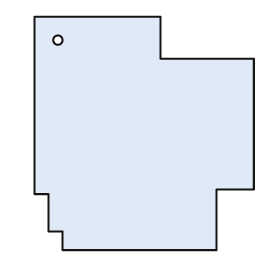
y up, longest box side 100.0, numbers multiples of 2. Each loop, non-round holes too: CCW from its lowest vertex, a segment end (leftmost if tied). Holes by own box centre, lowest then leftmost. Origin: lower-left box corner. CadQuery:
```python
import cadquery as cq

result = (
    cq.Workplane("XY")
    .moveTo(12.0, 0.0)
    .lineTo(78.0, 0.0)
    .lineTo(78.0, 26.0)
    .lineTo(94.0, 26.0)
    .lineTo(94.0, 82.0)
    .lineTo(54.0, 82.0)
    .lineTo(54.0, 100.0)
    .lineTo(0.0, 100.0)
    .lineTo(0.0, 24.0)
    .lineTo(6.0, 24.0)
    .lineTo(6.0, 8.0)
    .lineTo(12.0, 8.0)
    .close()
    .moveTo(10.0, 90.0)
    .circle(2.0)
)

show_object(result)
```